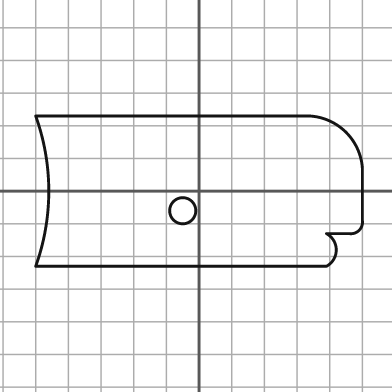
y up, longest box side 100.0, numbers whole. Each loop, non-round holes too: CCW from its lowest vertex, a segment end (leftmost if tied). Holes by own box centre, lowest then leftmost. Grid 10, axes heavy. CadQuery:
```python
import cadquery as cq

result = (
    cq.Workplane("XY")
    .moveTo(-50.0, -23.0)
    .lineTo(39.0, -23.0)
    .threePointArc((42.0, -18.0), (39.0, -13.0))
    .lineTo(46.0, -13.0)
    .threePointArc((49.0, -12.0), (50.0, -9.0))
    .lineTo(50.0, 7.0)
    .threePointArc((45.0, 18.0), (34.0, 23.0))
    .lineTo(-50.0, 23.0)
    .threePointArc((-46.0, 0.0), (-50.0, -23.0))
    .close()
    .moveTo(-5.0, -6.0)
    .circle(4.0)
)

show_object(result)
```